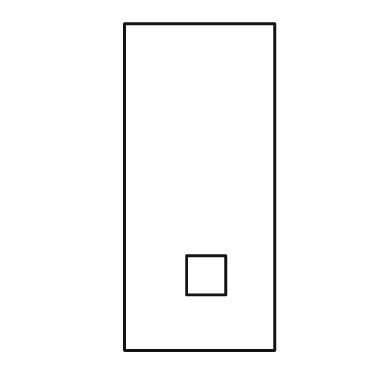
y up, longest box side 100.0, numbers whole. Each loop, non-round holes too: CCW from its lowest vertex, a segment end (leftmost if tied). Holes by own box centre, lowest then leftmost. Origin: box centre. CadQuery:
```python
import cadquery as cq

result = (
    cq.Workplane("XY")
    .moveTo(-23.0, -50.0)
    .lineTo(23.0, -50.0)
    .lineTo(23.0, 50.0)
    .lineTo(-23.0, 50.0)
    .close()
    .moveTo(-4.0, -33.0)
    .lineTo(8.0, -33.0)
    .lineTo(8.0, -21.0)
    .lineTo(-4.0, -21.0)
    .close()
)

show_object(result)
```